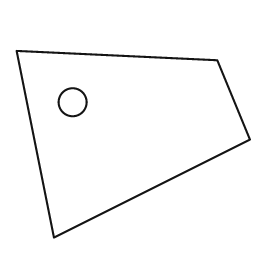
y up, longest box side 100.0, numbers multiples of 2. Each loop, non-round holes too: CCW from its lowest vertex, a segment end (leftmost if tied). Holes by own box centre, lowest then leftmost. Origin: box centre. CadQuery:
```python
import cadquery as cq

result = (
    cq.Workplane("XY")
    .moveTo(-34.0, -40.0)
    .lineTo(50.0, 2.0)
    .lineTo(36.0, 36.0)
    .lineTo(-50.0, 40.0)
    .close()
    .moveTo(-26.0, 18.0)
    .circle(6.0)
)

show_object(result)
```